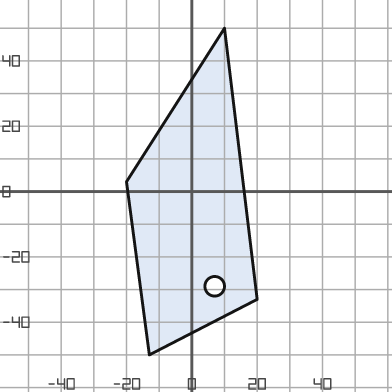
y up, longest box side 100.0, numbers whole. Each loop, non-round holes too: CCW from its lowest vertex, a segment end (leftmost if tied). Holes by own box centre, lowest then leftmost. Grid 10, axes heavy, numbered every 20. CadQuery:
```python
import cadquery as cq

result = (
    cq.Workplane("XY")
    .moveTo(-13.0, -50.0)
    .lineTo(20.0, -33.0)
    .lineTo(10.0, 50.0)
    .lineTo(-20.0, 3.0)
    .close()
    .moveTo(7.0, -29.0)
    .circle(3.0)
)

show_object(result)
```